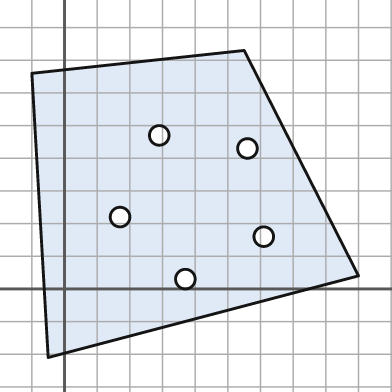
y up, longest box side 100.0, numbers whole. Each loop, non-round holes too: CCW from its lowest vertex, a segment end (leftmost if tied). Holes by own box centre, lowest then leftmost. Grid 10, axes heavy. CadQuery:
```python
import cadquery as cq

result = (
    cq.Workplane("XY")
    .moveTo(-5.0, -21.0)
    .lineTo(90.0, 4.0)
    .lineTo(55.0, 73.0)
    .lineTo(-10.0, 66.0)
    .close()
    .moveTo(37.0, 3.0)
    .circle(3.0)
    .moveTo(61.0, 16.0)
    .circle(3.0)
    .moveTo(17.0, 22.0)
    .circle(3.0)
    .moveTo(56.0, 43.0)
    .circle(3.0)
    .moveTo(29.0, 47.0)
    .circle(3.0)
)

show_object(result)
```